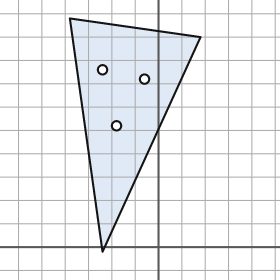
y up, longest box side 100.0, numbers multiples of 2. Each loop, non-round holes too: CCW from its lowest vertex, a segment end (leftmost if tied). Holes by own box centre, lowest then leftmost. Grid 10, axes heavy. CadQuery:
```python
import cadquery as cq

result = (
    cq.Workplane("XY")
    .moveTo(-24.0, -2.0)
    .lineTo(18.0, 90.0)
    .lineTo(-38.0, 98.0)
    .close()
    .moveTo(-18.0, 52.0)
    .circle(2.0)
    .moveTo(-6.0, 72.0)
    .circle(2.0)
    .moveTo(-24.0, 76.0)
    .circle(2.0)
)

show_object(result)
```